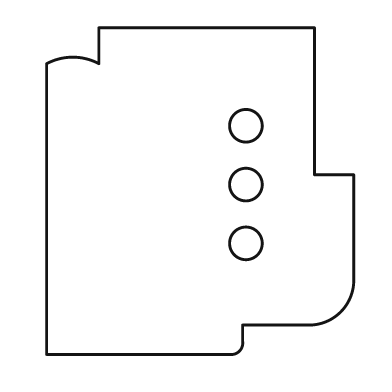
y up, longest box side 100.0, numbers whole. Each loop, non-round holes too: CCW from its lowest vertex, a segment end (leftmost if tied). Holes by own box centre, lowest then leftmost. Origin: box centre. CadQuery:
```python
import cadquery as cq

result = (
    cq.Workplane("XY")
    .moveTo(-47.0, -50.0)
    .lineTo(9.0, -50.0)
    .threePointArc((12.0, -49.0), (13.0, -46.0))
    .lineTo(13.0, -41.0)
    .lineTo(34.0, -41.0)
    .threePointArc((43.0, -37.0), (47.0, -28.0))
    .lineTo(47.0, 5.0)
    .lineTo(35.0, 5.0)
    .lineTo(35.0, 50.0)
    .lineTo(-31.0, 50.0)
    .lineTo(-31.0, 39.0)
    .threePointArc((-39.0, 41.0), (-47.0, 39.0))
    .close()
    .moveTo(14.0, -16.0)
    .circle(5.0)
    .moveTo(14.0, 2.0)
    .circle(5.0)
    .moveTo(14.0, 20.0)
    .circle(5.0)
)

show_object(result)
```